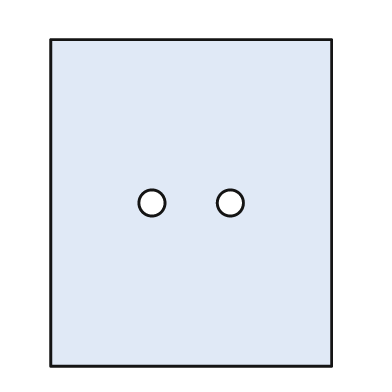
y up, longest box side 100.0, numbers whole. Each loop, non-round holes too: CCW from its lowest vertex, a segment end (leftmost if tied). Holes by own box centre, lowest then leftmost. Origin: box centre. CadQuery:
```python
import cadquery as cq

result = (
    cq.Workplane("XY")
    .moveTo(-43.0, -50.0)
    .lineTo(43.0, -50.0)
    .lineTo(43.0, 50.0)
    .lineTo(-43.0, 50.0)
    .close()
    .moveTo(-12.0, 0.0)
    .circle(4.0)
    .moveTo(12.0, 0.0)
    .circle(4.0)
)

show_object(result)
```